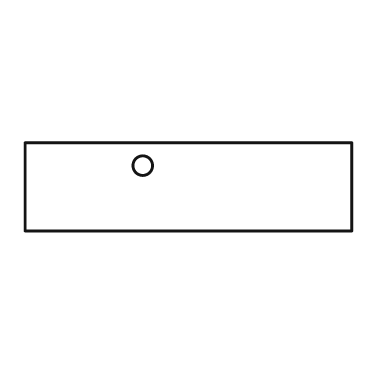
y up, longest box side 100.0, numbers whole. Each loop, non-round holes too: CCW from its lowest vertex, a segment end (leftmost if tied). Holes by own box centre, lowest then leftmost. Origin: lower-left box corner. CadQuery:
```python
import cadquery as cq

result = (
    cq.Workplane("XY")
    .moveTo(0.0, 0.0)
    .lineTo(100.0, 0.0)
    .lineTo(100.0, 27.0)
    .lineTo(0.0, 27.0)
    .close()
    .moveTo(36.0, 20.0)
    .circle(3.0)
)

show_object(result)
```